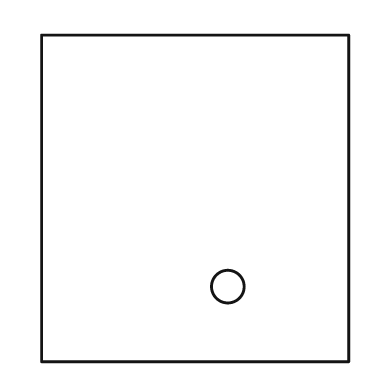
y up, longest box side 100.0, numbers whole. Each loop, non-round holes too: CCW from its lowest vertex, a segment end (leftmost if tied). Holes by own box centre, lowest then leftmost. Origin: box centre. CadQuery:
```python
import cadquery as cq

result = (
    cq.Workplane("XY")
    .moveTo(-47.0, -50.0)
    .lineTo(47.0, -50.0)
    .lineTo(47.0, 50.0)
    .lineTo(-47.0, 50.0)
    .close()
    .moveTo(10.0, -27.0)
    .circle(5.0)
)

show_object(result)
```